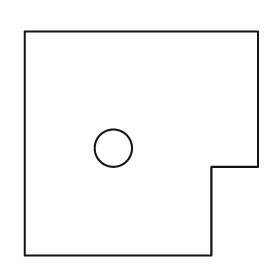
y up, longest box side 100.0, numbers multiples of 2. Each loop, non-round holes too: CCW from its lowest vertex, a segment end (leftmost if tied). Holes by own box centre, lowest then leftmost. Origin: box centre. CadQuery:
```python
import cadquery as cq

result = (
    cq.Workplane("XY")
    .moveTo(-50.0, -48.0)
    .lineTo(30.0, -48.0)
    .lineTo(30.0, -10.0)
    .lineTo(50.0, -10.0)
    .lineTo(50.0, 48.0)
    .lineTo(-50.0, 48.0)
    .close()
    .moveTo(-12.0, -2.0)
    .circle(8.0)
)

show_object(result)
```